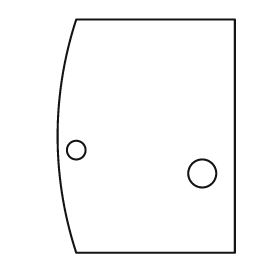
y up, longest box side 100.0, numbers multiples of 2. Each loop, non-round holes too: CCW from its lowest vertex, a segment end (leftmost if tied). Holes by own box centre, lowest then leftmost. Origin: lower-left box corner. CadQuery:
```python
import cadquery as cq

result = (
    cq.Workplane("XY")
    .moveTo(8.0, 0.0)
    .lineTo(76.0, 0.0)
    .lineTo(76.0, 100.0)
    .lineTo(8.0, 100.0)
    .threePointArc((0.0, 50.0), (8.0, 0.0))
    .close()
    .moveTo(62.0, 34.0)
    .circle(6.0)
    .moveTo(8.0, 44.0)
    .circle(4.0)
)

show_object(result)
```